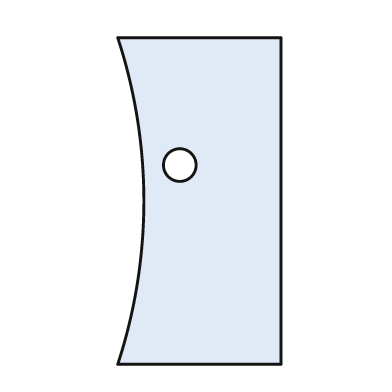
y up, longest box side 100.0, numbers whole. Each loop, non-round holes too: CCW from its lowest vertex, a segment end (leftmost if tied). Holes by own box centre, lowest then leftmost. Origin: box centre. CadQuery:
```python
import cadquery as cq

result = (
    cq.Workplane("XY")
    .moveTo(-25.0, -50.0)
    .lineTo(25.0, -50.0)
    .lineTo(25.0, 50.0)
    .lineTo(-25.0, 50.0)
    .threePointArc((-17.0, 0.0), (-25.0, -50.0))
    .close()
    .moveTo(-6.0, 11.0)
    .circle(5.0)
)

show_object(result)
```